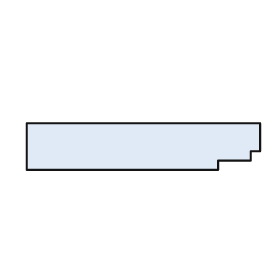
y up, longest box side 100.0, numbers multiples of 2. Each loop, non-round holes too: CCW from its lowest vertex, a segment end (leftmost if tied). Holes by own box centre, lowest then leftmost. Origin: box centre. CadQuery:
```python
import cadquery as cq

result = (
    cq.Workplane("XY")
    .moveTo(-50.0, -10.0)
    .lineTo(32.0, -10.0)
    .lineTo(32.0, -6.0)
    .lineTo(46.0, -6.0)
    .lineTo(46.0, -2.0)
    .lineTo(50.0, -2.0)
    .lineTo(50.0, 10.0)
    .lineTo(-50.0, 10.0)
    .close()
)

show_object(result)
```